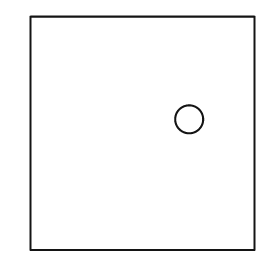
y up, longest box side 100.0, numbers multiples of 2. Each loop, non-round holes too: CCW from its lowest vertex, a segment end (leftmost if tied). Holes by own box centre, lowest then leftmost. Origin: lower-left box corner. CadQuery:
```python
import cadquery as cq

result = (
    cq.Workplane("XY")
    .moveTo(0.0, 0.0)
    .lineTo(96.0, 0.0)
    .lineTo(96.0, 100.0)
    .lineTo(0.0, 100.0)
    .close()
    .moveTo(68.0, 56.0)
    .circle(6.0)
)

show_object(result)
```